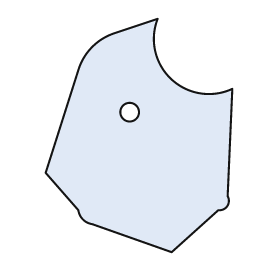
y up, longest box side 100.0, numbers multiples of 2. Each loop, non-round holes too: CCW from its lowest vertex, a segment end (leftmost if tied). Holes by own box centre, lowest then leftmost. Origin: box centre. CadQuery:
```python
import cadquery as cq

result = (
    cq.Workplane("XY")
    .moveTo(14.0, -50.0)
    .lineTo(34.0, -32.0)
    .threePointArc((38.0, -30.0), (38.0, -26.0))
    .lineTo(40.0, 20.0)
    .threePointArc((14.0, 24.0), (8.0, 50.0))
    .lineTo(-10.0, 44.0)
    .threePointArc((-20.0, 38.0), (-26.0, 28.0))
    .lineTo(-40.0, -16.0)
    .lineTo(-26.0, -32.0)
    .threePointArc((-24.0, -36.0), (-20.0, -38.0))
    .close()
    .moveTo(-4.0, 10.0)
    .circle(4.0)
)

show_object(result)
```